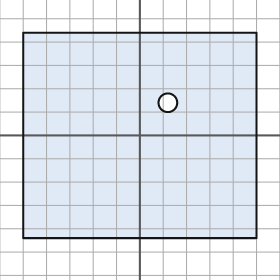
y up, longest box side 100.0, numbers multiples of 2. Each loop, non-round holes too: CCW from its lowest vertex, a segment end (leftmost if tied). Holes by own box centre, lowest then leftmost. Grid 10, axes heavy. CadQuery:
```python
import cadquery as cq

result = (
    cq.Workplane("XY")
    .moveTo(-50.0, -44.0)
    .lineTo(50.0, -44.0)
    .lineTo(50.0, 44.0)
    .lineTo(-50.0, 44.0)
    .close()
    .moveTo(12.0, 14.0)
    .circle(4.0)
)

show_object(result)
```